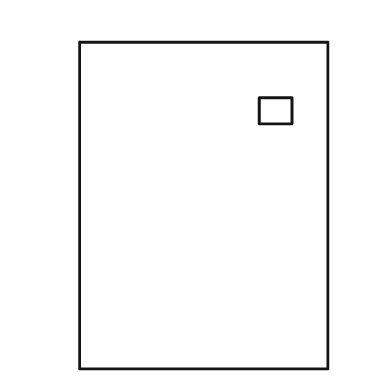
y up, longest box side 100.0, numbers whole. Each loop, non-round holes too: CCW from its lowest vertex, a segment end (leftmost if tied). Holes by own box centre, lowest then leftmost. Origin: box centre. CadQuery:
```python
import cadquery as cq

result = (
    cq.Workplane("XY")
    .moveTo(-38.0, -50.0)
    .lineTo(38.0, -50.0)
    .lineTo(38.0, 50.0)
    .lineTo(-38.0, 50.0)
    .close()
    .moveTo(17.0, 25.0)
    .lineTo(27.0, 25.0)
    .lineTo(27.0, 33.0)
    .lineTo(17.0, 33.0)
    .close()
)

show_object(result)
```